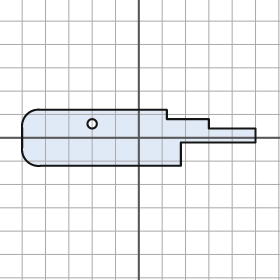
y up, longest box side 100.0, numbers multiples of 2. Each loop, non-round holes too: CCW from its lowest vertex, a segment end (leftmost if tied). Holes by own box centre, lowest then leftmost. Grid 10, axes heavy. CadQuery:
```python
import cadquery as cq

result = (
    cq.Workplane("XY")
    .moveTo(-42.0, -12.0)
    .lineTo(18.0, -12.0)
    .lineTo(18.0, -2.0)
    .lineTo(50.0, -2.0)
    .lineTo(50.0, 4.0)
    .lineTo(30.0, 4.0)
    .lineTo(30.0, 8.0)
    .lineTo(12.0, 8.0)
    .lineTo(12.0, 12.0)
    .lineTo(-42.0, 12.0)
    .threePointArc((-48.0, 10.0), (-50.0, 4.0))
    .lineTo(-50.0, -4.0)
    .threePointArc((-48.0, -10.0), (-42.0, -12.0))
    .close()
    .moveTo(-20.0, 6.0)
    .circle(2.0)
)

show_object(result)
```